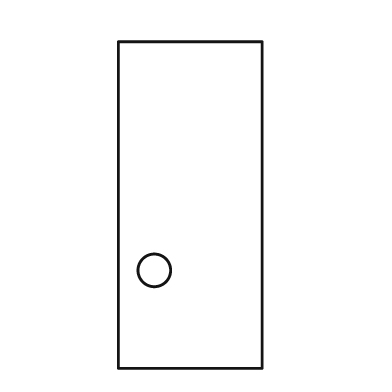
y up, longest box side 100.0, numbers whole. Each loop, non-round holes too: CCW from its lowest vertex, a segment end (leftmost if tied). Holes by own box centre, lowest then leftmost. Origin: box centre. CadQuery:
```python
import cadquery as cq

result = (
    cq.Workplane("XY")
    .moveTo(-22.0, -50.0)
    .lineTo(22.0, -50.0)
    .lineTo(22.0, 50.0)
    .lineTo(-22.0, 50.0)
    .close()
    .moveTo(-11.0, -20.0)
    .circle(5.0)
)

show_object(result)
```